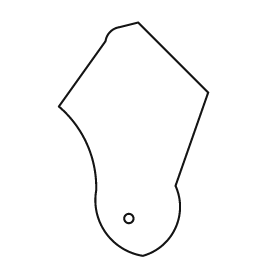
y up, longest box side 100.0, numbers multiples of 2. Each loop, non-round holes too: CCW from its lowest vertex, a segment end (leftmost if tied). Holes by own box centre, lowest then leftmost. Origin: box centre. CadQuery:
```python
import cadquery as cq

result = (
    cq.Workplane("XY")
    .moveTo(4.0, -50.0)
    .threePointArc((18.0, -38.0), (18.0, -20.0))
    .lineTo(32.0, 20.0)
    .lineTo(2.0, 50.0)
    .lineTo(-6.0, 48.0)
    .threePointArc((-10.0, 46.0), (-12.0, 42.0))
    .lineTo(-32.0, 14.0)
    .threePointArc((-20.0, -2.0), (-16.0, -22.0))
    .threePointArc((-12.0, -40.0), (4.0, -50.0))
    .close()
    .moveTo(-2.0, -34.0)
    .circle(2.0)
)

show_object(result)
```